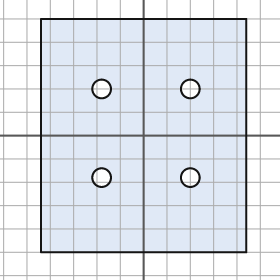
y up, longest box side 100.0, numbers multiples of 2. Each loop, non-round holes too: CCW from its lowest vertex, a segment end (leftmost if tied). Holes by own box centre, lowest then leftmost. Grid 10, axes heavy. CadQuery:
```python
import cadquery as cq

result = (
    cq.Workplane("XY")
    .moveTo(-44.0, -50.0)
    .lineTo(44.0, -50.0)
    .lineTo(44.0, 50.0)
    .lineTo(-44.0, 50.0)
    .close()
    .moveTo(-18.0, -18.0)
    .circle(4.0)
    .moveTo(20.0, -18.0)
    .circle(4.0)
    .moveTo(-18.0, 20.0)
    .circle(4.0)
    .moveTo(20.0, 20.0)
    .circle(4.0)
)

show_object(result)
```